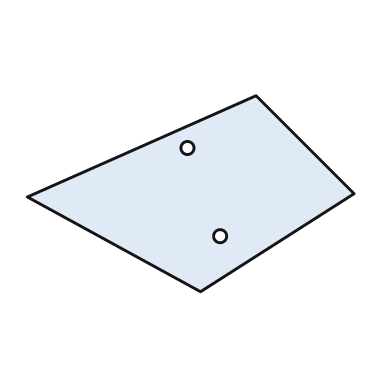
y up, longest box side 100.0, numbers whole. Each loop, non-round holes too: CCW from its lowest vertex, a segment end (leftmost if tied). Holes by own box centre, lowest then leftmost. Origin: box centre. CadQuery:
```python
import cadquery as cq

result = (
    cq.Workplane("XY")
    .moveTo(3.0, -30.0)
    .lineTo(50.0, 0.0)
    .lineTo(20.0, 30.0)
    .lineTo(-50.0, -1.0)
    .close()
    .moveTo(9.0, -13.0)
    .circle(2.0)
    .moveTo(-1.0, 14.0)
    .circle(2.0)
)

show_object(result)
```